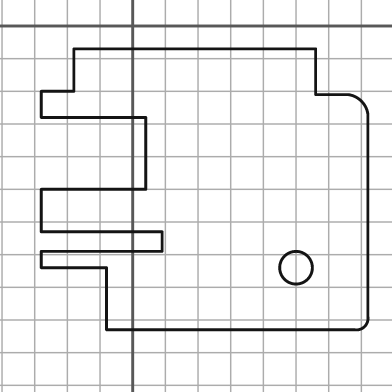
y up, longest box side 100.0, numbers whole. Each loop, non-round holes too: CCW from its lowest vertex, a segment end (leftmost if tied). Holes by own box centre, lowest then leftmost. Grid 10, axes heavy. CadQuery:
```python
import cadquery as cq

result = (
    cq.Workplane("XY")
    .moveTo(-8.0, -93.0)
    .lineTo(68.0, -93.0)
    .threePointArc((71.0, -92.0), (72.0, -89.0))
    .lineTo(72.0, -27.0)
    .threePointArc((70.0, -23.0), (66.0, -21.0))
    .lineTo(56.0, -21.0)
    .lineTo(56.0, -7.0)
    .lineTo(-18.0, -7.0)
    .lineTo(-18.0, -20.0)
    .lineTo(-28.0, -20.0)
    .lineTo(-28.0, -28.0)
    .lineTo(4.0, -28.0)
    .lineTo(4.0, -50.0)
    .lineTo(-28.0, -50.0)
    .lineTo(-28.0, -63.0)
    .lineTo(9.0, -63.0)
    .lineTo(9.0, -69.0)
    .lineTo(-28.0, -69.0)
    .lineTo(-28.0, -74.0)
    .lineTo(-8.0, -74.0)
    .close()
    .moveTo(50.0, -74.0)
    .circle(5.0)
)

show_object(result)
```